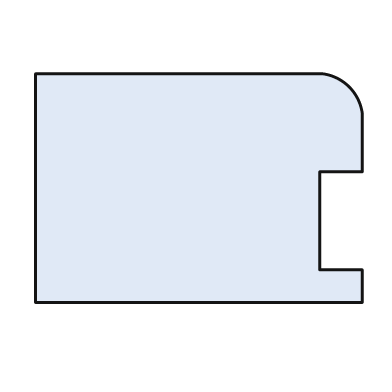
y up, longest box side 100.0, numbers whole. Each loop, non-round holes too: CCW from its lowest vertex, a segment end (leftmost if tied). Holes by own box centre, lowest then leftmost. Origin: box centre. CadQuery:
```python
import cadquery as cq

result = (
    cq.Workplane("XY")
    .moveTo(-50.0, -35.0)
    .lineTo(50.0, -35.0)
    .lineTo(50.0, -25.0)
    .lineTo(37.0, -25.0)
    .lineTo(37.0, 5.0)
    .lineTo(50.0, 5.0)
    .lineTo(50.0, 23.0)
    .threePointArc((46.0, 31.0), (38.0, 35.0))
    .lineTo(-50.0, 35.0)
    .close()
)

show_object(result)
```